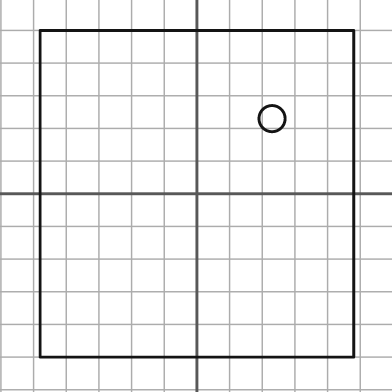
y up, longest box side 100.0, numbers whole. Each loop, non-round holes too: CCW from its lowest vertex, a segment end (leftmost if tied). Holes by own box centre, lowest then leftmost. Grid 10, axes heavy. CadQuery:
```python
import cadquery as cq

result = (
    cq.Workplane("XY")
    .moveTo(-48.0, -50.0)
    .lineTo(48.0, -50.0)
    .lineTo(48.0, 50.0)
    .lineTo(-48.0, 50.0)
    .close()
    .moveTo(23.0, 23.0)
    .circle(4.0)
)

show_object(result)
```